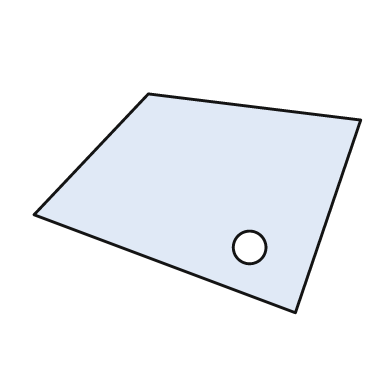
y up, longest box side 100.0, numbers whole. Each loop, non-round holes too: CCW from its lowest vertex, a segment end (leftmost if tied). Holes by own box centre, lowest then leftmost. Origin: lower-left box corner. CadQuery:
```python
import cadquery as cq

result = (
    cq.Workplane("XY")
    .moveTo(80.0, 0.0)
    .lineTo(100.0, 59.0)
    .lineTo(35.0, 67.0)
    .lineTo(0.0, 30.0)
    .close()
    .moveTo(66.0, 20.0)
    .circle(5.0)
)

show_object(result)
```